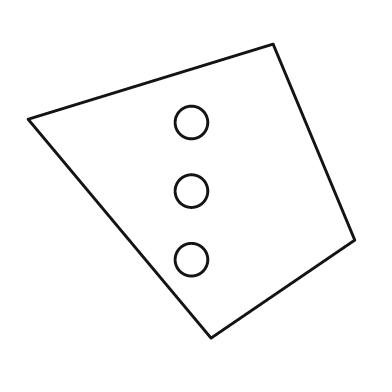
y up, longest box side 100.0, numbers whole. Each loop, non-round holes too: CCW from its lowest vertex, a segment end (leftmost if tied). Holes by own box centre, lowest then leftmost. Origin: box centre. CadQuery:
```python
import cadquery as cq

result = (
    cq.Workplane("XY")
    .moveTo(6.0, -45.0)
    .lineTo(50.0, -15.0)
    .lineTo(25.0, 45.0)
    .lineTo(-50.0, 22.0)
    .close()
    .moveTo(0.0, -21.0)
    .circle(5.0)
    .moveTo(0.0, 0.0)
    .circle(5.0)
    .moveTo(0.0, 21.0)
    .circle(5.0)
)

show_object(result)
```